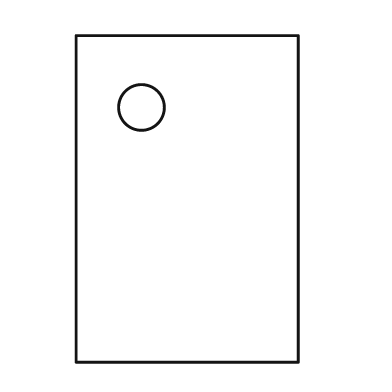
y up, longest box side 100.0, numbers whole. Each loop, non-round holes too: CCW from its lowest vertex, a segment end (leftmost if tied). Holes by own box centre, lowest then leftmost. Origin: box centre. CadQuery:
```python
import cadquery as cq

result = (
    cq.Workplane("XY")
    .moveTo(-34.0, -50.0)
    .lineTo(34.0, -50.0)
    .lineTo(34.0, 50.0)
    .lineTo(-34.0, 50.0)
    .close()
    .moveTo(-14.0, 28.0)
    .circle(7.0)
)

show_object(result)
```